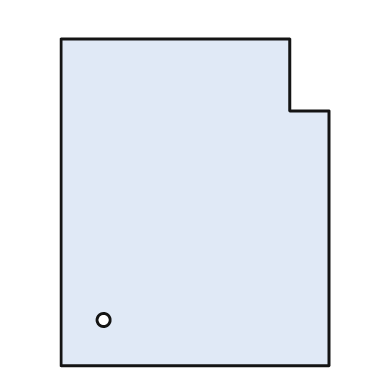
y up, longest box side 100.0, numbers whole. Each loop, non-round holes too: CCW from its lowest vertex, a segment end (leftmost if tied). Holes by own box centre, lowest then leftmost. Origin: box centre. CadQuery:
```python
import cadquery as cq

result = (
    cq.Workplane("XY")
    .moveTo(-41.0, -50.0)
    .lineTo(41.0, -50.0)
    .lineTo(41.0, 28.0)
    .lineTo(29.0, 28.0)
    .lineTo(29.0, 50.0)
    .lineTo(-41.0, 50.0)
    .close()
    .moveTo(-28.0, -36.0)
    .circle(2.0)
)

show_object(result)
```